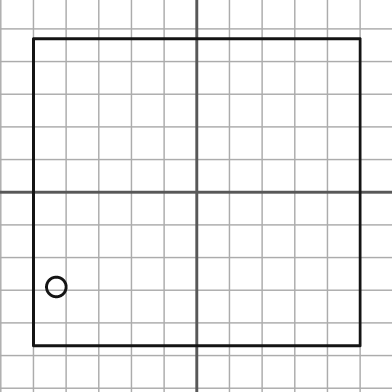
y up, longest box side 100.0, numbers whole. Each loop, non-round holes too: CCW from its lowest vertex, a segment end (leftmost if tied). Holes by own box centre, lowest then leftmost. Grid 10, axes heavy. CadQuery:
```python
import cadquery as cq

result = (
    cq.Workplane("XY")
    .moveTo(-50.0, -47.0)
    .lineTo(50.0, -47.0)
    .lineTo(50.0, 47.0)
    .lineTo(-50.0, 47.0)
    .close()
    .moveTo(-43.0, -29.0)
    .circle(3.0)
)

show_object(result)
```